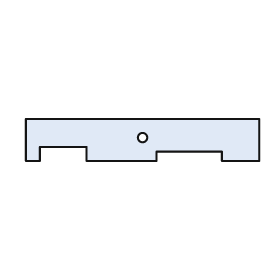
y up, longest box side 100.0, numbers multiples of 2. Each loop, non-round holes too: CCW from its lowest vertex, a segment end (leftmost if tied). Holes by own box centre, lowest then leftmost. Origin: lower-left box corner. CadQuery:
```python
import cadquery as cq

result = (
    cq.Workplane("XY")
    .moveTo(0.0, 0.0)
    .lineTo(6.0, 0.0)
    .lineTo(6.0, 6.0)
    .lineTo(26.0, 6.0)
    .lineTo(26.0, 0.0)
    .lineTo(56.0, 0.0)
    .lineTo(56.0, 4.0)
    .lineTo(84.0, 4.0)
    .lineTo(84.0, 0.0)
    .lineTo(100.0, 0.0)
    .lineTo(100.0, 18.0)
    .lineTo(0.0, 18.0)
    .close()
    .moveTo(50.0, 10.0)
    .circle(2.0)
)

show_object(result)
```